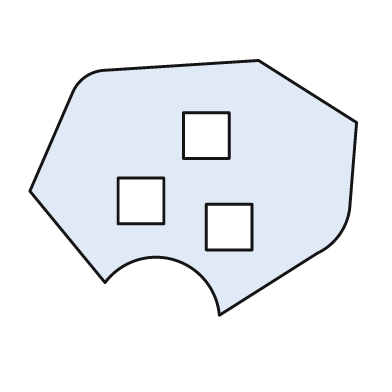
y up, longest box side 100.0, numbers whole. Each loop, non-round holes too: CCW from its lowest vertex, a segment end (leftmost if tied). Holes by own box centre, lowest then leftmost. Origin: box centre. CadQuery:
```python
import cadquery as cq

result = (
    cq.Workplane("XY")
    .moveTo(8.0, -39.0)
    .lineTo(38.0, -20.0)
    .threePointArc((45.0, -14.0), (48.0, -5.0))
    .lineTo(50.0, 20.0)
    .lineTo(20.0, 39.0)
    .lineTo(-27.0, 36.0)
    .threePointArc((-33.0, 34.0), (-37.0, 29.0))
    .lineTo(-50.0, -1.0)
    .lineTo(-27.0, -29.0)
    .threePointArc((-6.0, -22.0), (8.0, -39.0))
    .close()
    .moveTo(4.0, -19.0)
    .lineTo(18.0, -19.0)
    .lineTo(18.0, -5.0)
    .lineTo(4.0, -5.0)
    .close()
    .moveTo(-23.0, -11.0)
    .lineTo(-9.0, -11.0)
    .lineTo(-9.0, 3.0)
    .lineTo(-23.0, 3.0)
    .close()
    .moveTo(-3.0, 9.0)
    .lineTo(11.0, 9.0)
    .lineTo(11.0, 23.0)
    .lineTo(-3.0, 23.0)
    .close()
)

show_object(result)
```